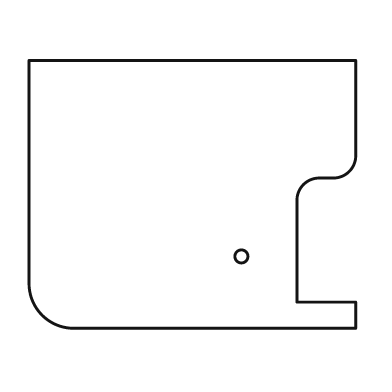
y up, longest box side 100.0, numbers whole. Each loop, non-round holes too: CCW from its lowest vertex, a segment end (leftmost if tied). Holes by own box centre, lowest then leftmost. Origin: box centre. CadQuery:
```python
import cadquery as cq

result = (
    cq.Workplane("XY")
    .moveTo(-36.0, -41.0)
    .lineTo(50.0, -41.0)
    .lineTo(50.0, -33.0)
    .lineTo(32.0, -33.0)
    .lineTo(32.0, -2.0)
    .threePointArc((34.0, 3.0), (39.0, 5.0))
    .lineTo(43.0, 5.0)
    .threePointArc((48.0, 7.0), (50.0, 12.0))
    .lineTo(50.0, 41.0)
    .lineTo(-50.0, 41.0)
    .lineTo(-50.0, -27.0)
    .threePointArc((-46.0, -37.0), (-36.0, -41.0))
    .close()
    .moveTo(15.0, -19.0)
    .circle(2.0)
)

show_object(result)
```